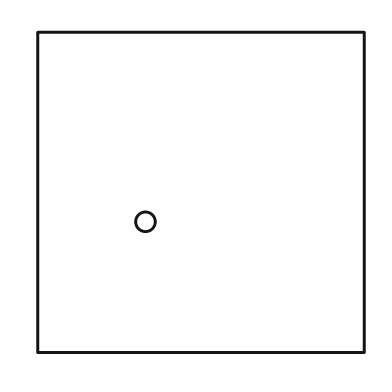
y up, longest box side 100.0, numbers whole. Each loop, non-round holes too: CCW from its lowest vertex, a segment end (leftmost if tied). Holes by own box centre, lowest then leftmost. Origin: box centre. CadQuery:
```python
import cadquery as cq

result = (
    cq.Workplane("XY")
    .moveTo(-50.0, -49.0)
    .lineTo(50.0, -49.0)
    .lineTo(50.0, 49.0)
    .lineTo(-50.0, 49.0)
    .close()
    .moveTo(-17.0, -9.0)
    .circle(3.0)
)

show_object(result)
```